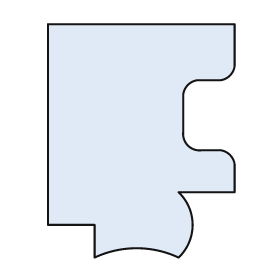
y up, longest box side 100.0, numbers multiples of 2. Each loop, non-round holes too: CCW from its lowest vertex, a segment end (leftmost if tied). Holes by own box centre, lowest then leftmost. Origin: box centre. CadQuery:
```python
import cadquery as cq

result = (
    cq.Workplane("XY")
    .moveTo(-20.0, -50.0)
    .threePointArc((-2.0, -46.0), (16.0, -50.0))
    .threePointArc((22.0, -36.0), (16.0, -22.0))
    .lineTo(40.0, -22.0)
    .lineTo(40.0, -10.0)
    .threePointArc((38.0, -6.0), (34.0, -4.0))
    .lineTo(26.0, -4.0)
    .threePointArc((20.0, -2.0), (18.0, 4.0))
    .lineTo(18.0, 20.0)
    .threePointArc((20.0, 24.0), (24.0, 26.0))
    .lineTo(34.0, 26.0)
    .threePointArc((38.0, 28.0), (40.0, 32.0))
    .lineTo(40.0, 50.0)
    .lineTo(-40.0, 50.0)
    .lineTo(-40.0, -36.0)
    .lineTo(-20.0, -36.0)
    .close()
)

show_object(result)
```